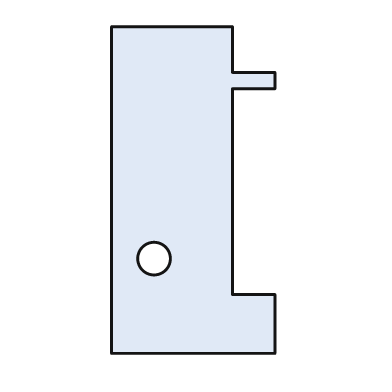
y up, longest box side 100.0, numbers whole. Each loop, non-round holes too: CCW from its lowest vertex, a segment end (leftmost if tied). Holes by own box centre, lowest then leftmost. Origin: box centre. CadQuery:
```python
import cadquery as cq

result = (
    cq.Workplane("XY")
    .moveTo(-25.0, -50.0)
    .lineTo(25.0, -50.0)
    .lineTo(25.0, -32.0)
    .lineTo(12.0, -32.0)
    .lineTo(12.0, 31.0)
    .lineTo(25.0, 31.0)
    .lineTo(25.0, 36.0)
    .lineTo(12.0, 36.0)
    .lineTo(12.0, 50.0)
    .lineTo(-25.0, 50.0)
    .close()
    .moveTo(-12.0, -21.0)
    .circle(5.0)
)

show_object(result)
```